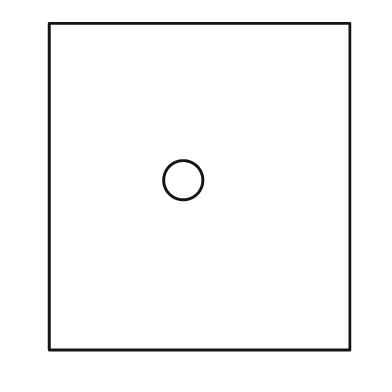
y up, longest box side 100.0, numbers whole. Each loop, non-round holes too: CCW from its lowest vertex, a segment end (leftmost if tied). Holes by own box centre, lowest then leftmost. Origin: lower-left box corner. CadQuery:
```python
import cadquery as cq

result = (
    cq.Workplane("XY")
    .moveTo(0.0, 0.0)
    .lineTo(92.0, 0.0)
    .lineTo(92.0, 100.0)
    .lineTo(0.0, 100.0)
    .close()
    .moveTo(41.0, 52.0)
    .circle(6.0)
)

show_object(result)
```